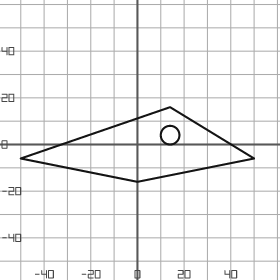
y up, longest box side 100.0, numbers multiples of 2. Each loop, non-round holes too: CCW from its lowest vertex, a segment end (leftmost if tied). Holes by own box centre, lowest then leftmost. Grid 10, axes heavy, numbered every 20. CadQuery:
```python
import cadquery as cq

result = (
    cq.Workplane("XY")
    .moveTo(0.0, -16.0)
    .lineTo(50.0, -6.0)
    .lineTo(14.0, 16.0)
    .lineTo(-50.0, -6.0)
    .close()
    .moveTo(14.0, 4.0)
    .circle(4.0)
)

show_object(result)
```